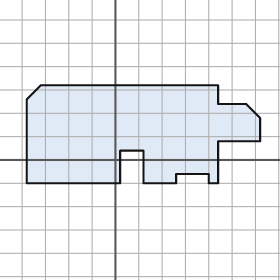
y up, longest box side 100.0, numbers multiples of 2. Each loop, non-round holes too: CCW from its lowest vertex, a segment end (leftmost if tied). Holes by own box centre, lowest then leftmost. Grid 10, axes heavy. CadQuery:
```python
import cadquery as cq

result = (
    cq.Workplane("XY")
    .moveTo(-38.0, -10.0)
    .lineTo(2.0, -10.0)
    .lineTo(2.0, 4.0)
    .lineTo(12.0, 4.0)
    .lineTo(12.0, -10.0)
    .lineTo(26.0, -10.0)
    .lineTo(26.0, -6.0)
    .lineTo(40.0, -6.0)
    .lineTo(40.0, -10.0)
    .lineTo(44.0, -10.0)
    .lineTo(44.0, 8.0)
    .lineTo(62.0, 8.0)
    .lineTo(62.0, 18.0)
    .lineTo(56.0, 24.0)
    .lineTo(44.0, 24.0)
    .lineTo(44.0, 32.0)
    .lineTo(-32.0, 32.0)
    .lineTo(-38.0, 26.0)
    .close()
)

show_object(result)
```